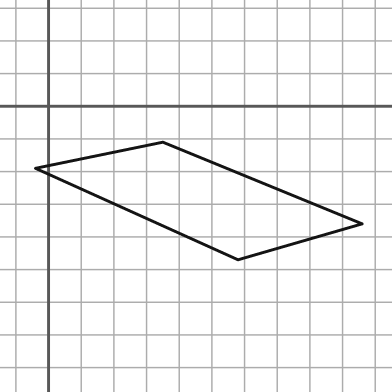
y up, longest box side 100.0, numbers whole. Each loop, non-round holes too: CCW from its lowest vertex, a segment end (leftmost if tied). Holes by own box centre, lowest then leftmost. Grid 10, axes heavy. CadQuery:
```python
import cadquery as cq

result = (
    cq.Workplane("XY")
    .moveTo(58.0, -47.0)
    .lineTo(96.0, -36.0)
    .lineTo(35.0, -11.0)
    .lineTo(-4.0, -19.0)
    .close()
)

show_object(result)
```